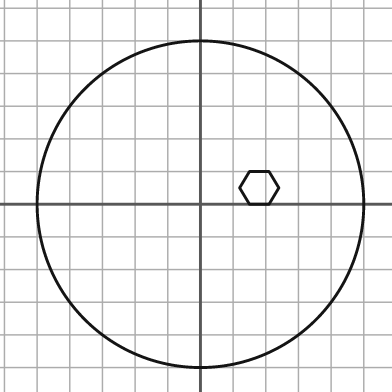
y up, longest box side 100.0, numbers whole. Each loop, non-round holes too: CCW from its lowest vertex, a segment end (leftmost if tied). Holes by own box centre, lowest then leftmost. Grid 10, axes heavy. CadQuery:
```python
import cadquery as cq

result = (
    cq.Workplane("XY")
    .moveTo(0.0, 0.0)
    .circle(50.0)
    .moveTo(15.0, 0.0)
    .lineTo(21.0, 0.0)
    .lineTo(24.0, 5.0)
    .lineTo(21.0, 10.0)
    .lineTo(15.0, 10.0)
    .lineTo(12.0, 5.0)
    .close()
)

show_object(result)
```